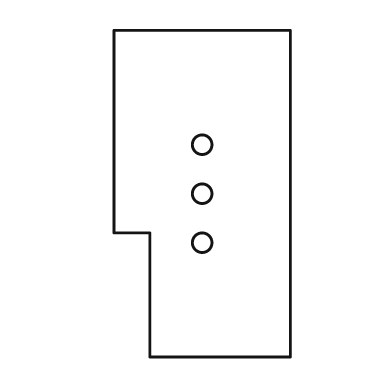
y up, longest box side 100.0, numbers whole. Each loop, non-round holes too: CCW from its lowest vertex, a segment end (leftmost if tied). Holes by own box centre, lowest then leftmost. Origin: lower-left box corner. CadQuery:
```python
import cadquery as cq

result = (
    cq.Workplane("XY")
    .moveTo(11.0, 0.0)
    .lineTo(54.0, 0.0)
    .lineTo(54.0, 100.0)
    .lineTo(0.0, 100.0)
    .lineTo(0.0, 38.0)
    .lineTo(11.0, 38.0)
    .close()
    .moveTo(27.0, 35.0)
    .circle(3.0)
    .moveTo(27.0, 50.0)
    .circle(3.0)
    .moveTo(27.0, 65.0)
    .circle(3.0)
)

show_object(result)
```